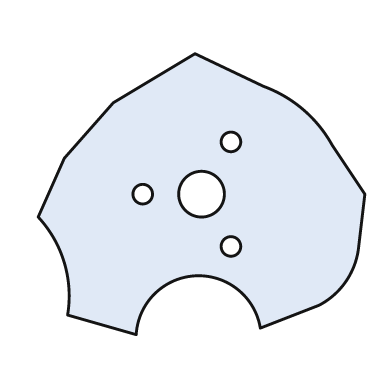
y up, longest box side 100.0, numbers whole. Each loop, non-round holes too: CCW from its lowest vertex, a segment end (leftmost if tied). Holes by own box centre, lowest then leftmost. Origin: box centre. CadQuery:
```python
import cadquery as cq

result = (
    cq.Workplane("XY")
    .moveTo(-20.0, -43.0)
    .threePointArc((-2.0, -25.0), (18.0, -41.0))
    .lineTo(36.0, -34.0)
    .threePointArc((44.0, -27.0), (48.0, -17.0))
    .lineTo(50.0, 0.0)
    .lineTo(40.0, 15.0)
    .threePointArc((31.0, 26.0), (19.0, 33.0))
    .lineTo(-2.0, 43.0)
    .lineTo(-27.0, 28.0)
    .lineTo(-42.0, 11.0)
    .lineTo(-50.0, -7.0)
    .threePointArc((-42.0, -21.0), (-41.0, -37.0))
    .close()
    .moveTo(9.0, -16.0)
    .circle(3.0)
    .moveTo(-18.0, 0.0)
    .circle(3.0)
    .moveTo(0.0, 0.0)
    .circle(7.0)
    .moveTo(9.0, 16.0)
    .circle(3.0)
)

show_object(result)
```